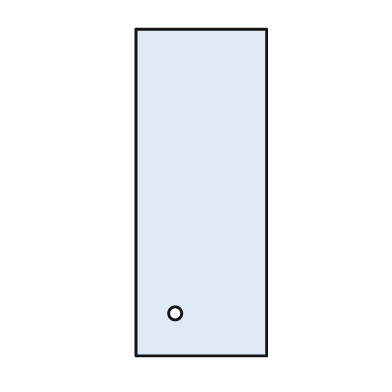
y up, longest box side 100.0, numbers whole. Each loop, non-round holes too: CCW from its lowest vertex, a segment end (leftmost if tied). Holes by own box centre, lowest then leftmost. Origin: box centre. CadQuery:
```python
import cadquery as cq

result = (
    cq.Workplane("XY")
    .moveTo(-20.0, -50.0)
    .lineTo(20.0, -50.0)
    .lineTo(20.0, 50.0)
    .lineTo(-20.0, 50.0)
    .close()
    .moveTo(-8.0, -37.0)
    .circle(2.0)
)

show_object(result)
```